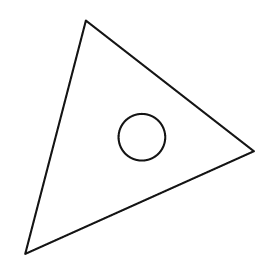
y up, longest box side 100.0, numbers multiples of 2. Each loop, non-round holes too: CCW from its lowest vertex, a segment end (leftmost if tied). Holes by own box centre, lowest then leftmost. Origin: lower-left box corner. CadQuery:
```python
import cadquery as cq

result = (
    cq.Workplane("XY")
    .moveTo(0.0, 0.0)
    .lineTo(98.0, 44.0)
    .lineTo(26.0, 100.0)
    .close()
    .moveTo(50.0, 50.0)
    .circle(10.0)
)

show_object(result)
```